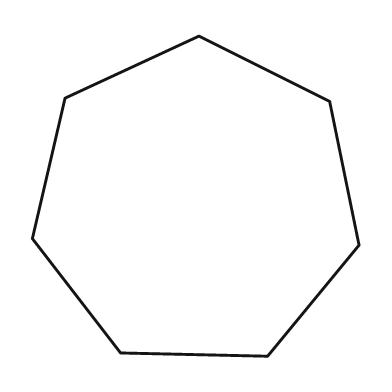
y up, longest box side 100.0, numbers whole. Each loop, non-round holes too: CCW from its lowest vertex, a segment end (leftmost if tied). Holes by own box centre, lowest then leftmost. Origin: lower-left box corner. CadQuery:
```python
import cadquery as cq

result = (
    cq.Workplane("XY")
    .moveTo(72.0, 0.0)
    .lineTo(100.0, 34.0)
    .lineTo(91.0, 78.0)
    .lineTo(51.0, 98.0)
    .lineTo(10.0, 79.0)
    .lineTo(0.0, 36.0)
    .lineTo(27.0, 1.0)
    .close()
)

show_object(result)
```